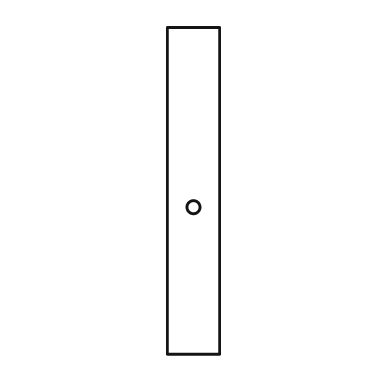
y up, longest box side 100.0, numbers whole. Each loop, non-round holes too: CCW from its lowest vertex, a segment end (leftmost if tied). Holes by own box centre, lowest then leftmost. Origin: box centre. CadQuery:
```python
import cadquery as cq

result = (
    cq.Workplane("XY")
    .moveTo(-8.0, -50.0)
    .lineTo(8.0, -50.0)
    .lineTo(8.0, 50.0)
    .lineTo(-8.0, 50.0)
    .close()
    .moveTo(0.0, -5.0)
    .circle(2.0)
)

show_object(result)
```